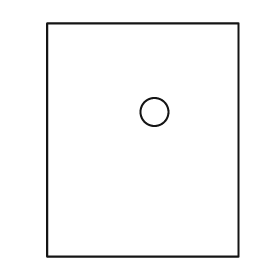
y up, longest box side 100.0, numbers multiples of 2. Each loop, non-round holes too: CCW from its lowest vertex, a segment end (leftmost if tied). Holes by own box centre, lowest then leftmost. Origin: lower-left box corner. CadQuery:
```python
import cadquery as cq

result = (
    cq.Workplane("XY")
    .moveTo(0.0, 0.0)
    .lineTo(82.0, 0.0)
    .lineTo(82.0, 100.0)
    .lineTo(0.0, 100.0)
    .close()
    .moveTo(46.0, 62.0)
    .circle(6.0)
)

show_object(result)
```